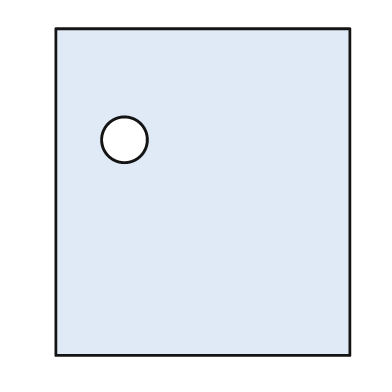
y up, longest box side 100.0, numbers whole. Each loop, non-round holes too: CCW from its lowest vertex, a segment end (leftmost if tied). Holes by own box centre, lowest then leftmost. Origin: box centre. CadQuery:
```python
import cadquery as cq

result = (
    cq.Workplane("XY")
    .moveTo(-45.0, -50.0)
    .lineTo(45.0, -50.0)
    .lineTo(45.0, 50.0)
    .lineTo(-45.0, 50.0)
    .close()
    .moveTo(-24.0, 16.0)
    .circle(7.0)
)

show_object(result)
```